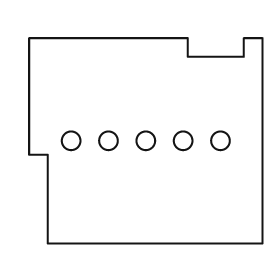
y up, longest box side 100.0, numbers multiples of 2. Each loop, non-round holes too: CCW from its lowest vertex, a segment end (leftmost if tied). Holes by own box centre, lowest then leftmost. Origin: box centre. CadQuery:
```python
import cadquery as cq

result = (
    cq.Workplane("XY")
    .moveTo(-42.0, -44.0)
    .lineTo(50.0, -44.0)
    .lineTo(50.0, 44.0)
    .lineTo(42.0, 44.0)
    .lineTo(42.0, 36.0)
    .lineTo(18.0, 36.0)
    .lineTo(18.0, 44.0)
    .lineTo(-50.0, 44.0)
    .lineTo(-50.0, -6.0)
    .lineTo(-42.0, -6.0)
    .close()
    .moveTo(-32.0, 0.0)
    .circle(4.0)
    .moveTo(-16.0, 0.0)
    .circle(4.0)
    .moveTo(0.0, 0.0)
    .circle(4.0)
    .moveTo(16.0, 0.0)
    .circle(4.0)
    .moveTo(32.0, 0.0)
    .circle(4.0)
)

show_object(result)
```